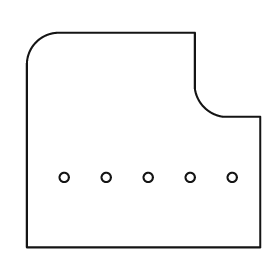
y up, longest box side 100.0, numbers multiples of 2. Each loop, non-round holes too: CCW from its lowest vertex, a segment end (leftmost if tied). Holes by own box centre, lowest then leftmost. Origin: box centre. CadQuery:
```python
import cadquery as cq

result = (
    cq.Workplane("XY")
    .moveTo(-50.0, -46.0)
    .lineTo(50.0, -46.0)
    .lineTo(50.0, 10.0)
    .lineTo(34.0, 10.0)
    .threePointArc((26.0, 14.0), (22.0, 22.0))
    .lineTo(22.0, 46.0)
    .lineTo(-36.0, 46.0)
    .threePointArc((-46.0, 42.0), (-50.0, 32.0))
    .close()
    .moveTo(-34.0, -16.0)
    .circle(2.0)
    .moveTo(-16.0, -16.0)
    .circle(2.0)
    .moveTo(2.0, -16.0)
    .circle(2.0)
    .moveTo(20.0, -16.0)
    .circle(2.0)
    .moveTo(38.0, -16.0)
    .circle(2.0)
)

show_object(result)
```